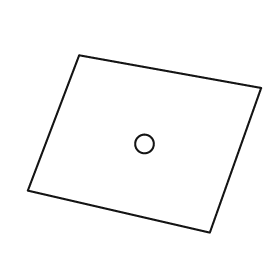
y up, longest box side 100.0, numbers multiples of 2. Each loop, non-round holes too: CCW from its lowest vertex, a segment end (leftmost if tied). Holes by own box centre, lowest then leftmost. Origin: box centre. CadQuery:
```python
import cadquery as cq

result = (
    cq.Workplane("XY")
    .moveTo(28.0, -38.0)
    .lineTo(50.0, 24.0)
    .lineTo(-28.0, 38.0)
    .lineTo(-50.0, -20.0)
    .close()
    .moveTo(0.0, 0.0)
    .circle(4.0)
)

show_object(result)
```